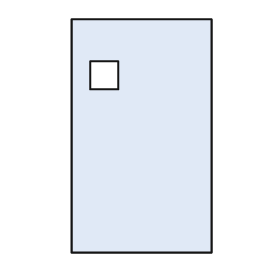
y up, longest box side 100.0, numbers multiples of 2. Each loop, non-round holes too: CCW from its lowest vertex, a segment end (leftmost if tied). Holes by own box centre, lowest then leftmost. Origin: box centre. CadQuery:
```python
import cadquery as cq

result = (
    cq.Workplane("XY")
    .moveTo(-30.0, -50.0)
    .lineTo(30.0, -50.0)
    .lineTo(30.0, 50.0)
    .lineTo(-30.0, 50.0)
    .close()
    .moveTo(-22.0, 20.0)
    .lineTo(-10.0, 20.0)
    .lineTo(-10.0, 32.0)
    .lineTo(-22.0, 32.0)
    .close()
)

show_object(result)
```